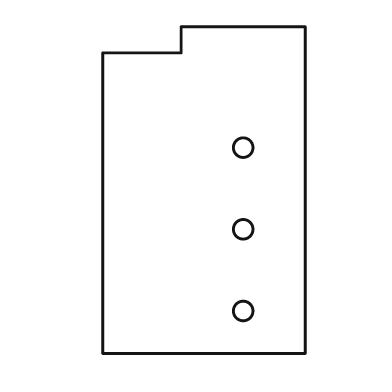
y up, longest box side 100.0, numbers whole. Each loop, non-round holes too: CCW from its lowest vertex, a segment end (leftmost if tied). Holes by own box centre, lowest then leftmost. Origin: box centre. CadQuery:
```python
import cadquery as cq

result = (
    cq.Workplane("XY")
    .moveTo(-31.0, -50.0)
    .lineTo(31.0, -50.0)
    .lineTo(31.0, 50.0)
    .lineTo(-7.0, 50.0)
    .lineTo(-7.0, 42.0)
    .lineTo(-31.0, 42.0)
    .close()
    .moveTo(12.0, -37.0)
    .circle(3.0)
    .moveTo(12.0, -12.0)
    .circle(3.0)
    .moveTo(12.0, 13.0)
    .circle(3.0)
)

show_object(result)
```